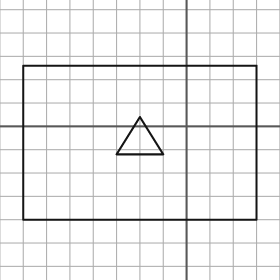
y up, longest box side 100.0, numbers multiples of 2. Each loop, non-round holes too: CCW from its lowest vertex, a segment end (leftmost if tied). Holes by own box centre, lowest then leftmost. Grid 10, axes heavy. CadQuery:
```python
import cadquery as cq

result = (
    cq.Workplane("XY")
    .moveTo(-70.0, -40.0)
    .lineTo(30.0, -40.0)
    .lineTo(30.0, 26.0)
    .lineTo(-70.0, 26.0)
    .close()
    .moveTo(-30.0, -12.0)
    .lineTo(-10.0, -12.0)
    .lineTo(-20.0, 4.0)
    .close()
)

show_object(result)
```